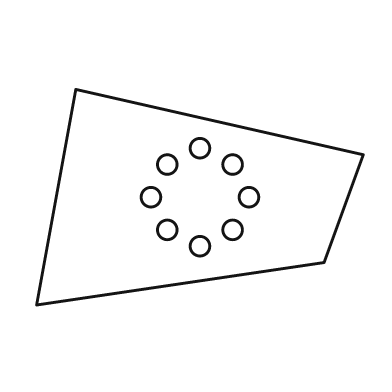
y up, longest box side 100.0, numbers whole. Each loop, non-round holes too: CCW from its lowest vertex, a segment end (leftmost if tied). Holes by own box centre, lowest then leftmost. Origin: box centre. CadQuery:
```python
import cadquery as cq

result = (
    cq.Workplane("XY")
    .moveTo(-50.0, -33.0)
    .lineTo(38.0, -20.0)
    .lineTo(50.0, 13.0)
    .lineTo(-38.0, 33.0)
    .close()
    .moveTo(0.0, -15.0)
    .circle(3.0)
    .moveTo(-10.0, -10.0)
    .circle(3.0)
    .moveTo(10.0, -10.0)
    .circle(3.0)
    .moveTo(-15.0, 0.0)
    .circle(3.0)
    .moveTo(15.0, 0.0)
    .circle(3.0)
    .moveTo(-10.0, 10.0)
    .circle(3.0)
    .moveTo(10.0, 10.0)
    .circle(3.0)
    .moveTo(0.0, 15.0)
    .circle(3.0)
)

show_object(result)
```